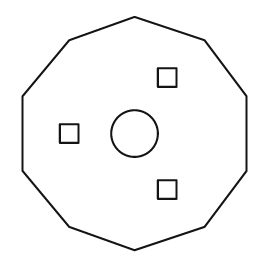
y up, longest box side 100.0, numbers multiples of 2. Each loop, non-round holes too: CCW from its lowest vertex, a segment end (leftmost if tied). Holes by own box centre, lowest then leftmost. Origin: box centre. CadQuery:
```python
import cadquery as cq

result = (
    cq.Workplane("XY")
    .moveTo(0.0, -50.0)
    .lineTo(30.0, -40.0)
    .lineTo(48.0, -16.0)
    .lineTo(48.0, 16.0)
    .lineTo(30.0, 40.0)
    .lineTo(0.0, 50.0)
    .lineTo(-28.0, 40.0)
    .lineTo(-48.0, 16.0)
    .lineTo(-48.0, -16.0)
    .lineTo(-28.0, -40.0)
    .close()
    .moveTo(10.0, -28.0)
    .lineTo(18.0, -28.0)
    .lineTo(18.0, -20.0)
    .lineTo(10.0, -20.0)
    .close()
    .moveTo(-32.0, -4.0)
    .lineTo(-24.0, -4.0)
    .lineTo(-24.0, 4.0)
    .lineTo(-32.0, 4.0)
    .close()
    .moveTo(0.0, 0.0)
    .circle(10.0)
    .moveTo(10.0, 20.0)
    .lineTo(18.0, 20.0)
    .lineTo(18.0, 28.0)
    .lineTo(10.0, 28.0)
    .close()
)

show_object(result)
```